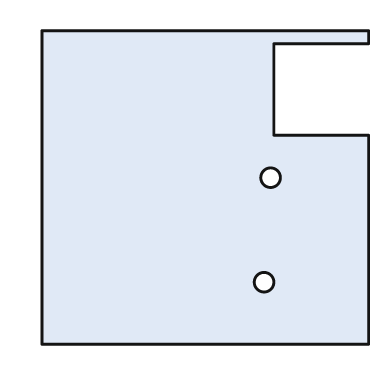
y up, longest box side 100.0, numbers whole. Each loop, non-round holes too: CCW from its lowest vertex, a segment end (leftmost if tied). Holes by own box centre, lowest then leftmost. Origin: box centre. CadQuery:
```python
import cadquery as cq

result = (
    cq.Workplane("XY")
    .moveTo(-50.0, -48.0)
    .lineTo(50.0, -48.0)
    .lineTo(50.0, 16.0)
    .lineTo(21.0, 16.0)
    .lineTo(21.0, 44.0)
    .lineTo(50.0, 44.0)
    .lineTo(50.0, 48.0)
    .lineTo(-50.0, 48.0)
    .close()
    .moveTo(18.0, -29.0)
    .circle(3.0)
    .moveTo(20.0, 3.0)
    .circle(3.0)
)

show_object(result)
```